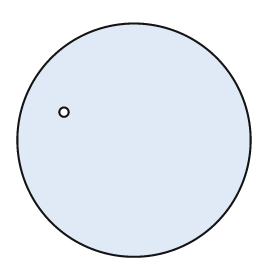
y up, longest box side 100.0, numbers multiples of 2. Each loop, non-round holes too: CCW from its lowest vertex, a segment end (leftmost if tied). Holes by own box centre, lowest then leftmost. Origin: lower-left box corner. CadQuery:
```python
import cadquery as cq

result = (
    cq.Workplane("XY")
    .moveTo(50.0, 50.0)
    .circle(50.0)
    .moveTo(20.0, 62.0)
    .circle(2.0)
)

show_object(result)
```